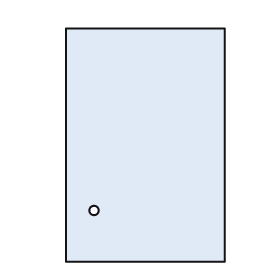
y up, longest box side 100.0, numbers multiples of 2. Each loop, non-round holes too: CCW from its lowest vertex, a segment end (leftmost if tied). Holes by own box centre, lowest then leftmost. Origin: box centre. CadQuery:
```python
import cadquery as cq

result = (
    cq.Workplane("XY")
    .moveTo(-34.0, -50.0)
    .lineTo(34.0, -50.0)
    .lineTo(34.0, 50.0)
    .lineTo(-34.0, 50.0)
    .close()
    .moveTo(-22.0, -28.0)
    .circle(2.0)
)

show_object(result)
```